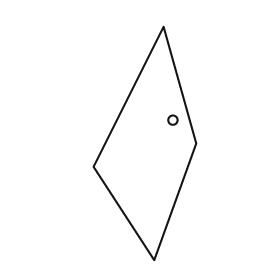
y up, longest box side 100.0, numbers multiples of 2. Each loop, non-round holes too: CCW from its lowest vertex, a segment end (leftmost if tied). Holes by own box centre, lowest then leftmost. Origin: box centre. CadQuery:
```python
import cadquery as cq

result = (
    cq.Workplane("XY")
    .moveTo(4.0, -50.0)
    .lineTo(22.0, 0.0)
    .lineTo(8.0, 50.0)
    .lineTo(-22.0, -10.0)
    .close()
    .moveTo(12.0, 10.0)
    .circle(2.0)
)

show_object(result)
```